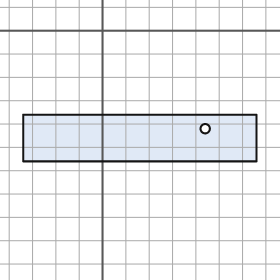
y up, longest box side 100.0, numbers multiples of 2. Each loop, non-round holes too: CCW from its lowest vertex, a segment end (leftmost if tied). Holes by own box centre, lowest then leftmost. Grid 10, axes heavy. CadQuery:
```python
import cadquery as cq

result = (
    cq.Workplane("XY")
    .moveTo(-34.0, -56.0)
    .lineTo(66.0, -56.0)
    .lineTo(66.0, -36.0)
    .lineTo(-34.0, -36.0)
    .close()
    .moveTo(44.0, -42.0)
    .circle(2.0)
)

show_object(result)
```